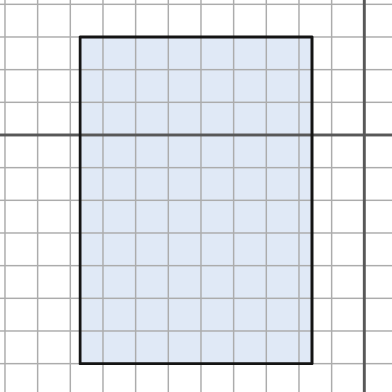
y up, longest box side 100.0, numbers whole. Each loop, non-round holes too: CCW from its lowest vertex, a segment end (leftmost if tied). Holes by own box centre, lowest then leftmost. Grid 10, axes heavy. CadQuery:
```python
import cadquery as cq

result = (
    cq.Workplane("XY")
    .moveTo(-87.0, -70.0)
    .lineTo(-16.0, -70.0)
    .lineTo(-16.0, 30.0)
    .lineTo(-87.0, 30.0)
    .close()
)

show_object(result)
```